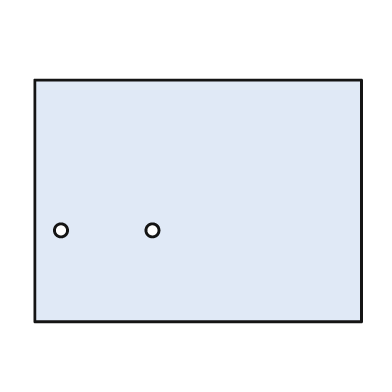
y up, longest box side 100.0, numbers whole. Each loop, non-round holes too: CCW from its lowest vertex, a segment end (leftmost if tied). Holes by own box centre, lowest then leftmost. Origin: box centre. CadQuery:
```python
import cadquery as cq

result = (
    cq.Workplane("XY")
    .moveTo(-50.0, -37.0)
    .lineTo(50.0, -37.0)
    .lineTo(50.0, 37.0)
    .lineTo(-50.0, 37.0)
    .close()
    .moveTo(-42.0, -9.0)
    .circle(2.0)
    .moveTo(-14.0, -9.0)
    .circle(2.0)
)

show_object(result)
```